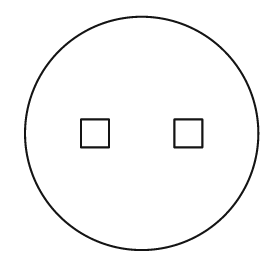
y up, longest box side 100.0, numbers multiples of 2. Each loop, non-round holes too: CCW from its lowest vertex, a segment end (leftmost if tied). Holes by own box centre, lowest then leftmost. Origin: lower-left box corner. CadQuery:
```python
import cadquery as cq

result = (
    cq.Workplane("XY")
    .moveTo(50.0, 50.0)
    .circle(50.0)
    .moveTo(24.0, 44.0)
    .lineTo(36.0, 44.0)
    .lineTo(36.0, 56.0)
    .lineTo(24.0, 56.0)
    .close()
    .moveTo(64.0, 44.0)
    .lineTo(76.0, 44.0)
    .lineTo(76.0, 56.0)
    .lineTo(64.0, 56.0)
    .close()
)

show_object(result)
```